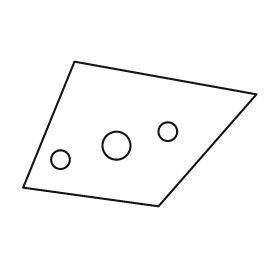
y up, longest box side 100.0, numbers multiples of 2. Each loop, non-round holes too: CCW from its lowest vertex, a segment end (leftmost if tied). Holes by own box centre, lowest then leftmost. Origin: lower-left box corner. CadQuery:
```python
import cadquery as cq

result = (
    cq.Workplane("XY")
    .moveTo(58.0, 0.0)
    .lineTo(100.0, 48.0)
    .lineTo(22.0, 62.0)
    .lineTo(0.0, 8.0)
    .close()
    .moveTo(16.0, 20.0)
    .circle(4.0)
    .moveTo(40.0, 26.0)
    .circle(6.0)
    .moveTo(62.0, 32.0)
    .circle(4.0)
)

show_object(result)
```